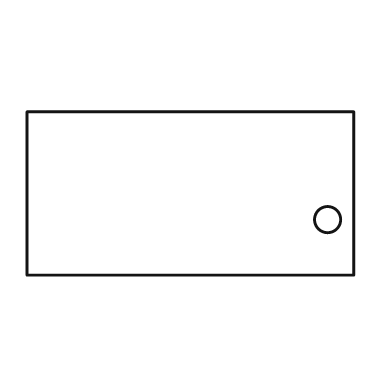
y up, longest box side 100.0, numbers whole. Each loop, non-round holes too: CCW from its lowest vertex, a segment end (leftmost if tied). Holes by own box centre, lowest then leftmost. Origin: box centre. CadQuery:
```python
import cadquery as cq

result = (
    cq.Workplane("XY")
    .moveTo(-50.0, -25.0)
    .lineTo(50.0, -25.0)
    .lineTo(50.0, 25.0)
    .lineTo(-50.0, 25.0)
    .close()
    .moveTo(42.0, -8.0)
    .circle(4.0)
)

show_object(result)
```